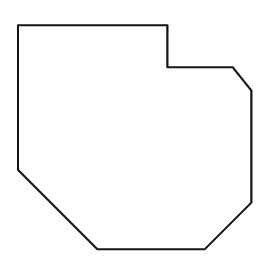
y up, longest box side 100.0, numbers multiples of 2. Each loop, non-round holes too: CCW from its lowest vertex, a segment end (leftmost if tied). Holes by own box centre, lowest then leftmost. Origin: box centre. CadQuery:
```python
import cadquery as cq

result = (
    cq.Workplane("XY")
    .moveTo(-16.0, -48.0)
    .lineTo(30.0, -48.0)
    .lineTo(50.0, -28.0)
    .lineTo(50.0, 20.0)
    .lineTo(42.0, 30.0)
    .lineTo(14.0, 30.0)
    .lineTo(14.0, 48.0)
    .lineTo(-50.0, 48.0)
    .lineTo(-50.0, -14.0)
    .close()
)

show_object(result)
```